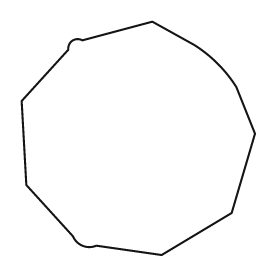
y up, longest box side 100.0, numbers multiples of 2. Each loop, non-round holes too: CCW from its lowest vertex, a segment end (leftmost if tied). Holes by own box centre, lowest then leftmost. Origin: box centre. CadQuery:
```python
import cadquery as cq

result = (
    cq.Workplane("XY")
    .moveTo(10.0, -50.0)
    .lineTo(40.0, -32.0)
    .lineTo(50.0, 2.0)
    .lineTo(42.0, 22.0)
    .threePointArc((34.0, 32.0), (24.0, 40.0))
    .lineTo(6.0, 50.0)
    .lineTo(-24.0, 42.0)
    .threePointArc((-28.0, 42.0), (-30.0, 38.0))
    .lineTo(-50.0, 16.0)
    .lineTo(-48.0, -20.0)
    .lineTo(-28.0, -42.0)
    .threePointArc((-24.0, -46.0), (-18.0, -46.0))
    .close()
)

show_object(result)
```